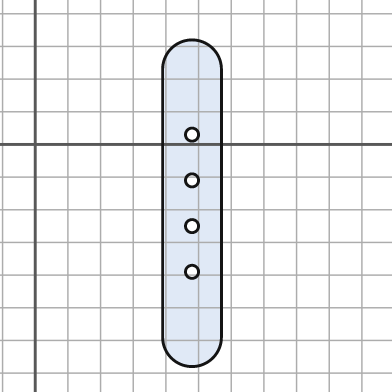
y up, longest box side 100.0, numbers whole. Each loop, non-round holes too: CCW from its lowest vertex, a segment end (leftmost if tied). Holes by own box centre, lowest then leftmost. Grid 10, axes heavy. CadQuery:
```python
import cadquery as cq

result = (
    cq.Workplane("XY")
    .moveTo(39.0, -59.0)
    .threePointArc((48.0, -68.0), (57.0, -59.0))
    .lineTo(57.0, 23.0)
    .threePointArc((48.0, 32.0), (39.0, 23.0))
    .close()
    .moveTo(48.0, -39.0)
    .circle(2.0)
    .moveTo(48.0, -25.0)
    .circle(2.0)
    .moveTo(48.0, -11.0)
    .circle(2.0)
    .moveTo(48.0, 3.0)
    .circle(2.0)
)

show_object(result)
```